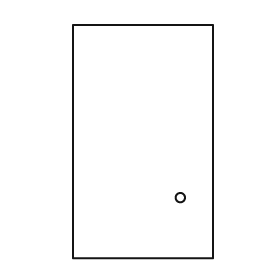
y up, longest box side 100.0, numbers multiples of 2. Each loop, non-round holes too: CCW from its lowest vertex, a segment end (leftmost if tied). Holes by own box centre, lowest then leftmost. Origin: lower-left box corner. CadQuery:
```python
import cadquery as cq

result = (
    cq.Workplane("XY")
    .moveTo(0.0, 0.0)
    .lineTo(60.0, 0.0)
    .lineTo(60.0, 100.0)
    .lineTo(0.0, 100.0)
    .close()
    .moveTo(46.0, 26.0)
    .circle(2.0)
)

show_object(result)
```